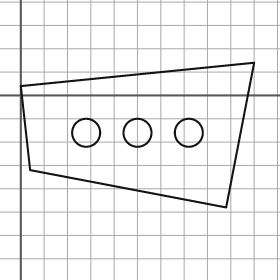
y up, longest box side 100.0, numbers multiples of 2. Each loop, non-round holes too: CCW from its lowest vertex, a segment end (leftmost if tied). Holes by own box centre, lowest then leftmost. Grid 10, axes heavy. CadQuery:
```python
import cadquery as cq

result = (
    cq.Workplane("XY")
    .moveTo(88.0, -48.0)
    .lineTo(100.0, 14.0)
    .lineTo(0.0, 4.0)
    .lineTo(4.0, -32.0)
    .close()
    .moveTo(28.0, -16.0)
    .circle(6.0)
    .moveTo(50.0, -16.0)
    .circle(6.0)
    .moveTo(72.0, -16.0)
    .circle(6.0)
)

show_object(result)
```